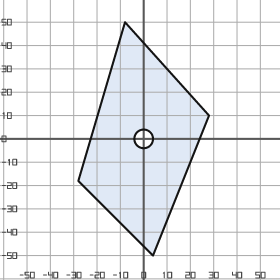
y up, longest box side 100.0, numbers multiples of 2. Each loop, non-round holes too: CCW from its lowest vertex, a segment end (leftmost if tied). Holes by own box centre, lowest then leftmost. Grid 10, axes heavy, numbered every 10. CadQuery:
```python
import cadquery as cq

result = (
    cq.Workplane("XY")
    .moveTo(4.0, -50.0)
    .lineTo(28.0, 10.0)
    .lineTo(-8.0, 50.0)
    .lineTo(-28.0, -18.0)
    .close()
    .moveTo(0.0, 0.0)
    .circle(4.0)
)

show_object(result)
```